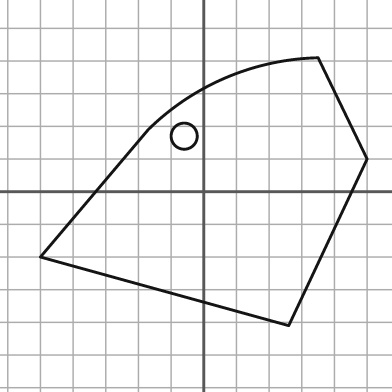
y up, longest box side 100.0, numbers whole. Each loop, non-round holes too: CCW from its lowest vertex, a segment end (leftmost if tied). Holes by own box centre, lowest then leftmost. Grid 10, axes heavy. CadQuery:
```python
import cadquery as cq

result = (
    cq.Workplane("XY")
    .moveTo(26.0, -41.0)
    .lineTo(50.0, 10.0)
    .lineTo(35.0, 41.0)
    .threePointArc((7.0, 35.0), (-17.0, 19.0))
    .lineTo(-50.0, -20.0)
    .close()
    .moveTo(-6.0, 17.0)
    .circle(4.0)
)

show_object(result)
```